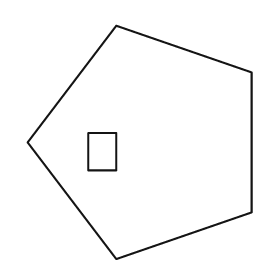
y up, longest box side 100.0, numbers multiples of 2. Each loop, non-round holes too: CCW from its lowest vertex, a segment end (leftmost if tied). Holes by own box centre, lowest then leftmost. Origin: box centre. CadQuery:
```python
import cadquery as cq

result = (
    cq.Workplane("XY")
    .moveTo(-10.0, -50.0)
    .lineTo(48.0, -30.0)
    .lineTo(48.0, 30.0)
    .lineTo(-10.0, 50.0)
    .lineTo(-48.0, 0.0)
    .close()
    .moveTo(-22.0, -12.0)
    .lineTo(-10.0, -12.0)
    .lineTo(-10.0, 4.0)
    .lineTo(-22.0, 4.0)
    .close()
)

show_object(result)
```